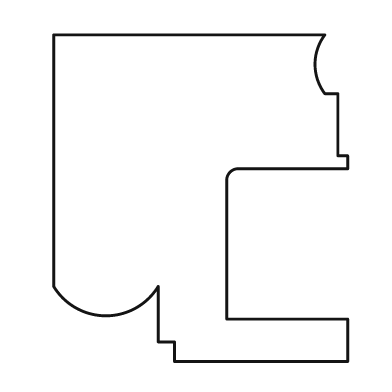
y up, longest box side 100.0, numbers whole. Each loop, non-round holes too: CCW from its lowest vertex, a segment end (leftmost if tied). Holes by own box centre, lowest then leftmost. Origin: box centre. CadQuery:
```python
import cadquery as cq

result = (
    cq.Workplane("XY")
    .moveTo(-8.0, -50.0)
    .lineTo(45.0, -50.0)
    .lineTo(45.0, -37.0)
    .lineTo(8.0, -37.0)
    .lineTo(8.0, 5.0)
    .threePointArc((9.0, 8.0), (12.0, 9.0))
    .lineTo(45.0, 9.0)
    .lineTo(45.0, 13.0)
    .lineTo(42.0, 13.0)
    .lineTo(42.0, 32.0)
    .lineTo(38.0, 32.0)
    .threePointArc((35.0, 41.0), (38.0, 50.0))
    .lineTo(-45.0, 50.0)
    .lineTo(-45.0, -27.0)
    .threePointArc((-29.0, -36.0), (-13.0, -27.0))
    .lineTo(-13.0, -44.0)
    .lineTo(-8.0, -44.0)
    .close()
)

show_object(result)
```